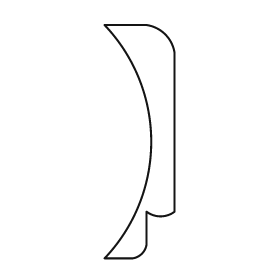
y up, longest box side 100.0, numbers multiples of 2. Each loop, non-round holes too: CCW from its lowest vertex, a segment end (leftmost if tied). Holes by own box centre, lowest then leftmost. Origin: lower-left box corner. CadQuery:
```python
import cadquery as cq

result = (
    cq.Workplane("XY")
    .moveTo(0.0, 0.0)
    .lineTo(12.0, 0.0)
    .threePointArc((16.0, 2.0), (18.0, 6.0))
    .lineTo(18.0, 20.0)
    .threePointArc((24.0, 18.0), (30.0, 20.0))
    .lineTo(30.0, 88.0)
    .threePointArc((26.0, 96.0), (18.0, 100.0))
    .lineTo(0.0, 100.0)
    .threePointArc((20.0, 50.0), (0.0, 0.0))
    .close()
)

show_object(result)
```